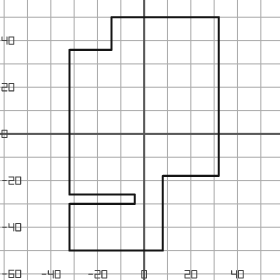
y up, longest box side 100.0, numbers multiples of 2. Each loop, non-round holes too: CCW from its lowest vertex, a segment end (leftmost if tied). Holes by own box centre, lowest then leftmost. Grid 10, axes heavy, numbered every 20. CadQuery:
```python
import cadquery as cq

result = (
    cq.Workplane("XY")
    .moveTo(-32.0, -50.0)
    .lineTo(8.0, -50.0)
    .lineTo(8.0, -18.0)
    .lineTo(32.0, -18.0)
    .lineTo(32.0, 50.0)
    .lineTo(-14.0, 50.0)
    .lineTo(-14.0, 36.0)
    .lineTo(-32.0, 36.0)
    .lineTo(-32.0, -26.0)
    .lineTo(-4.0, -26.0)
    .lineTo(-4.0, -30.0)
    .lineTo(-32.0, -30.0)
    .close()
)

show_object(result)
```